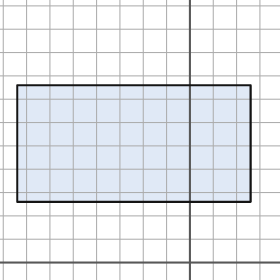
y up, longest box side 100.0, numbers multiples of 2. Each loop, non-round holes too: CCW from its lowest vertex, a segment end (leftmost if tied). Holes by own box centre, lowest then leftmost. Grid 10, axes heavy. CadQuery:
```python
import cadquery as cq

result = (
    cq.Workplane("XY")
    .moveTo(-74.0, 26.0)
    .lineTo(26.0, 26.0)
    .lineTo(26.0, 76.0)
    .lineTo(-74.0, 76.0)
    .close()
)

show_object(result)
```